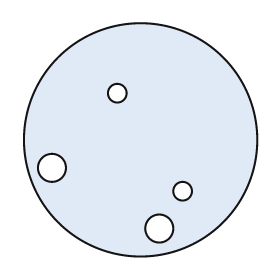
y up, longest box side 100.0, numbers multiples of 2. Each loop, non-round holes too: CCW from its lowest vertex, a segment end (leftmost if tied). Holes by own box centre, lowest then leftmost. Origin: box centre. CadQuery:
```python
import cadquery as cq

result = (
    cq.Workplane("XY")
    .moveTo(0.0, 0.0)
    .circle(50.0)
    .moveTo(8.0, -38.0)
    .circle(6.0)
    .moveTo(18.0, -22.0)
    .circle(4.0)
    .moveTo(-38.0, -12.0)
    .circle(6.0)
    .moveTo(-10.0, 20.0)
    .circle(4.0)
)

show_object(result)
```